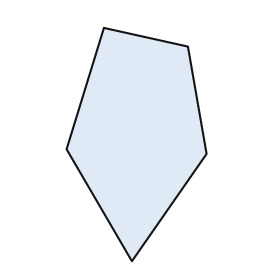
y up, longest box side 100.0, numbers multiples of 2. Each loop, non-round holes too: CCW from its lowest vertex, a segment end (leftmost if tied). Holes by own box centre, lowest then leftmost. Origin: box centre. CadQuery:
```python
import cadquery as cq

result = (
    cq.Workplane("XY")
    .moveTo(-2.0, -50.0)
    .lineTo(30.0, -4.0)
    .lineTo(22.0, 42.0)
    .lineTo(-14.0, 50.0)
    .lineTo(-30.0, -2.0)
    .close()
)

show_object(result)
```